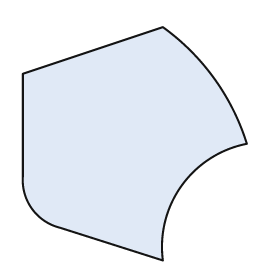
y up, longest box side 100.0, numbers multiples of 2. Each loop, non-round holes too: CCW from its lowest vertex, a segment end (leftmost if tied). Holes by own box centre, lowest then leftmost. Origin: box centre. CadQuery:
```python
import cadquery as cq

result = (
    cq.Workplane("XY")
    .moveTo(12.0, -50.0)
    .threePointArc((20.0, -18.0), (48.0, 0.0))
    .threePointArc((34.0, 28.0), (12.0, 50.0))
    .lineTo(-48.0, 30.0)
    .lineTo(-48.0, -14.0)
    .threePointArc((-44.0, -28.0), (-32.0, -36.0))
    .close()
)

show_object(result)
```